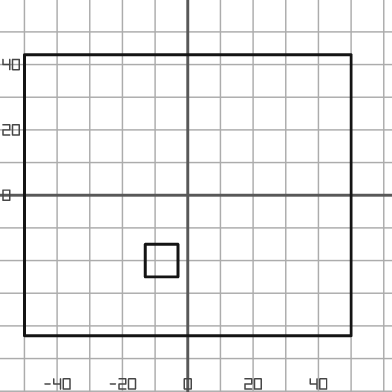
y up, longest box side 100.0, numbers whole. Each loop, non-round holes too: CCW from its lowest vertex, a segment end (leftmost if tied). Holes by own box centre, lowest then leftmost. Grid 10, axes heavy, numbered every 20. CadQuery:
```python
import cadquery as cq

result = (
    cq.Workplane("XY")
    .moveTo(-50.0, -43.0)
    .lineTo(50.0, -43.0)
    .lineTo(50.0, 43.0)
    .lineTo(-50.0, 43.0)
    .close()
    .moveTo(-13.0, -25.0)
    .lineTo(-3.0, -25.0)
    .lineTo(-3.0, -15.0)
    .lineTo(-13.0, -15.0)
    .close()
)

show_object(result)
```